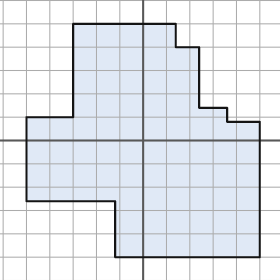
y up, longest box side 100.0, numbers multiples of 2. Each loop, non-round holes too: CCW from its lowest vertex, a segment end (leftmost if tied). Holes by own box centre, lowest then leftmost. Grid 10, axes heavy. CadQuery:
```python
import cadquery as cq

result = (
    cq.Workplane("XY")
    .moveTo(-12.0, -50.0)
    .lineTo(50.0, -50.0)
    .lineTo(50.0, 8.0)
    .lineTo(36.0, 8.0)
    .lineTo(36.0, 14.0)
    .lineTo(24.0, 14.0)
    .lineTo(24.0, 40.0)
    .lineTo(14.0, 40.0)
    .lineTo(14.0, 50.0)
    .lineTo(-30.0, 50.0)
    .lineTo(-30.0, 10.0)
    .lineTo(-50.0, 10.0)
    .lineTo(-50.0, -26.0)
    .lineTo(-12.0, -26.0)
    .close()
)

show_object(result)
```